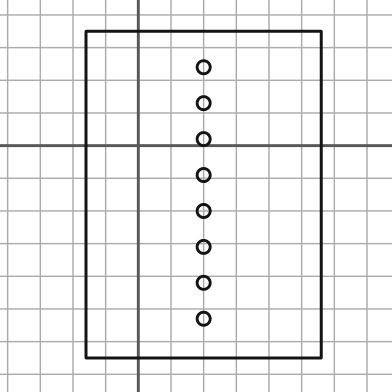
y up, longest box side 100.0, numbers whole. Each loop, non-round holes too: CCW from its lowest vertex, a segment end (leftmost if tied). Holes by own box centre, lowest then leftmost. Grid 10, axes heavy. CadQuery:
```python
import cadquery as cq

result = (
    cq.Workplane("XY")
    .moveTo(-16.0, -65.0)
    .lineTo(56.0, -65.0)
    .lineTo(56.0, 35.0)
    .lineTo(-16.0, 35.0)
    .close()
    .moveTo(20.0, -53.0)
    .circle(2.0)
    .moveTo(20.0, -42.0)
    .circle(2.0)
    .moveTo(20.0, -31.0)
    .circle(2.0)
    .moveTo(20.0, -20.0)
    .circle(2.0)
    .moveTo(20.0, -9.0)
    .circle(2.0)
    .moveTo(20.0, 2.0)
    .circle(2.0)
    .moveTo(20.0, 13.0)
    .circle(2.0)
    .moveTo(20.0, 24.0)
    .circle(2.0)
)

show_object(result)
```